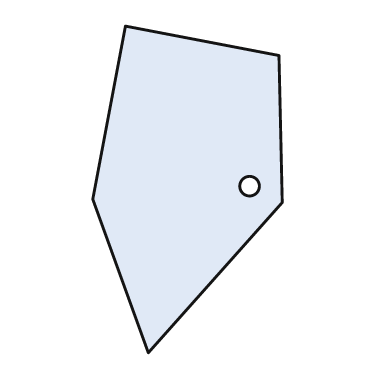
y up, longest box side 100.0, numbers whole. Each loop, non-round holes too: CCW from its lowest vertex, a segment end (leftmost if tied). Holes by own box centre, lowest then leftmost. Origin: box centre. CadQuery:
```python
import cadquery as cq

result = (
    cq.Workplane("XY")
    .moveTo(-12.0, -50.0)
    .lineTo(29.0, -4.0)
    .lineTo(28.0, 41.0)
    .lineTo(-19.0, 50.0)
    .lineTo(-29.0, -3.0)
    .close()
    .moveTo(19.0, 1.0)
    .circle(3.0)
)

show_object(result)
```